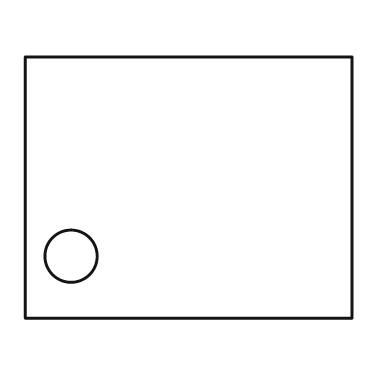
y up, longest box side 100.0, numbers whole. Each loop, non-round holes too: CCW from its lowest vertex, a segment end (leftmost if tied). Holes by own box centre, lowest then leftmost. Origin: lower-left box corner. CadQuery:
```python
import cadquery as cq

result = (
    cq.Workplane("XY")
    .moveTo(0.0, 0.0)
    .lineTo(100.0, 0.0)
    .lineTo(100.0, 80.0)
    .lineTo(0.0, 80.0)
    .close()
    .moveTo(14.0, 19.0)
    .circle(8.0)
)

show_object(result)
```